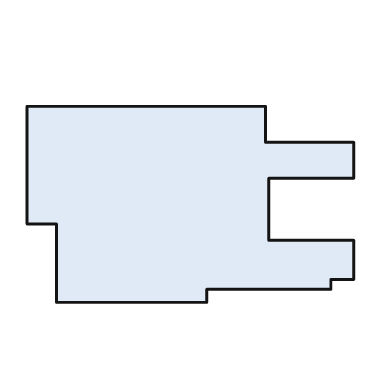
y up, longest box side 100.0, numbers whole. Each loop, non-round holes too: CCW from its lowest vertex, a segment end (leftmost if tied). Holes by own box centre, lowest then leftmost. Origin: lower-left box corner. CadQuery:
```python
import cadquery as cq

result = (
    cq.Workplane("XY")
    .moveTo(9.0, 0.0)
    .lineTo(55.0, 0.0)
    .lineTo(55.0, 4.0)
    .lineTo(93.0, 4.0)
    .lineTo(93.0, 7.0)
    .lineTo(100.0, 7.0)
    .lineTo(100.0, 19.0)
    .lineTo(74.0, 19.0)
    .lineTo(74.0, 38.0)
    .lineTo(100.0, 38.0)
    .lineTo(100.0, 49.0)
    .lineTo(73.0, 49.0)
    .lineTo(73.0, 60.0)
    .lineTo(0.0, 60.0)
    .lineTo(0.0, 24.0)
    .lineTo(9.0, 24.0)
    .close()
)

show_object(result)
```